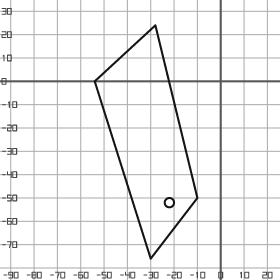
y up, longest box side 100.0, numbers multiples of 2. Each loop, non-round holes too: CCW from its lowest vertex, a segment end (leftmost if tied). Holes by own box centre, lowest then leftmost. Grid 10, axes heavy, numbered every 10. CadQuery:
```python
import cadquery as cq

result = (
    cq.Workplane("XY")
    .moveTo(-30.0, -76.0)
    .lineTo(-10.0, -50.0)
    .lineTo(-28.0, 24.0)
    .lineTo(-54.0, 0.0)
    .close()
    .moveTo(-22.0, -52.0)
    .circle(2.0)
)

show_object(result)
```